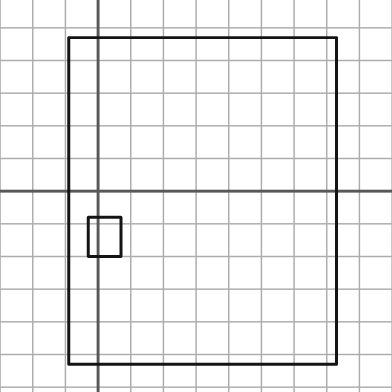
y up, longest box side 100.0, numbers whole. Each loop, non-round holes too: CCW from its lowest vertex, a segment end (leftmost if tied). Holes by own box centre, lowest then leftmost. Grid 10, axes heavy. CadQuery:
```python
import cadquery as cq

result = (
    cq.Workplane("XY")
    .moveTo(-9.0, -53.0)
    .lineTo(73.0, -53.0)
    .lineTo(73.0, 47.0)
    .lineTo(-9.0, 47.0)
    .close()
    .moveTo(-3.0, -20.0)
    .lineTo(7.0, -20.0)
    .lineTo(7.0, -8.0)
    .lineTo(-3.0, -8.0)
    .close()
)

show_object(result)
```